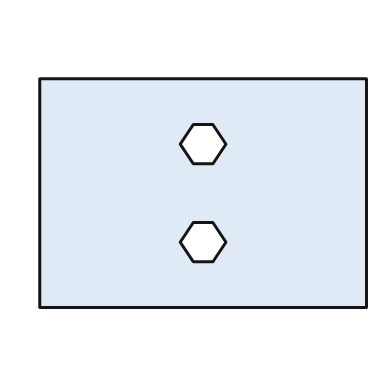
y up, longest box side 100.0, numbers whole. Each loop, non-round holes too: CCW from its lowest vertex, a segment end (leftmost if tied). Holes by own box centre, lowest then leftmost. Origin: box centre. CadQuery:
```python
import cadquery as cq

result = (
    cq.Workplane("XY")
    .moveTo(-50.0, -35.0)
    .lineTo(50.0, -35.0)
    .lineTo(50.0, 35.0)
    .lineTo(-50.0, 35.0)
    .close()
    .moveTo(-3.0, -21.0)
    .lineTo(3.0, -21.0)
    .lineTo(7.0, -15.0)
    .lineTo(3.0, -9.0)
    .lineTo(-3.0, -9.0)
    .lineTo(-7.0, -15.0)
    .close()
    .moveTo(-3.0, 9.0)
    .lineTo(3.0, 9.0)
    .lineTo(7.0, 15.0)
    .lineTo(3.0, 21.0)
    .lineTo(-3.0, 21.0)
    .lineTo(-7.0, 15.0)
    .close()
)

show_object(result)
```